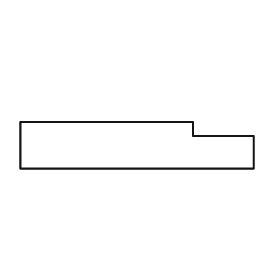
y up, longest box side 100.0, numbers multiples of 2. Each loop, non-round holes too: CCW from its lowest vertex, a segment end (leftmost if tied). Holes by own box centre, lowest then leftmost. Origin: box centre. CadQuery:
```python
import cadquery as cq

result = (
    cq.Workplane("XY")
    .moveTo(-50.0, -10.0)
    .lineTo(50.0, -10.0)
    .lineTo(50.0, 4.0)
    .lineTo(24.0, 4.0)
    .lineTo(24.0, 10.0)
    .lineTo(-50.0, 10.0)
    .close()
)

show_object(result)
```